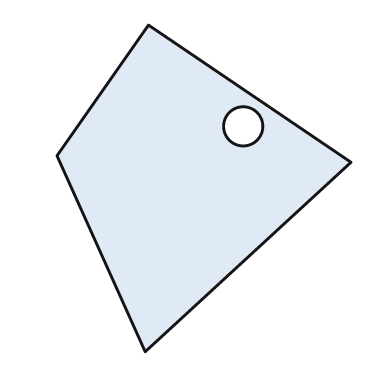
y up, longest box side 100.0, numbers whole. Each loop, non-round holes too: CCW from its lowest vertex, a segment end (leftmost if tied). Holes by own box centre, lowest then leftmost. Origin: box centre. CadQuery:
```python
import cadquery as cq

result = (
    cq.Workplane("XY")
    .moveTo(-18.0, -50.0)
    .lineTo(45.0, 8.0)
    .lineTo(-17.0, 50.0)
    .lineTo(-45.0, 10.0)
    .close()
    .moveTo(12.0, 19.0)
    .circle(6.0)
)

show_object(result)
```